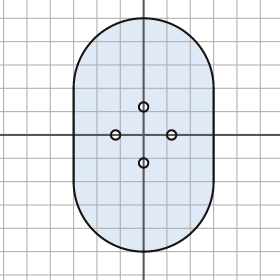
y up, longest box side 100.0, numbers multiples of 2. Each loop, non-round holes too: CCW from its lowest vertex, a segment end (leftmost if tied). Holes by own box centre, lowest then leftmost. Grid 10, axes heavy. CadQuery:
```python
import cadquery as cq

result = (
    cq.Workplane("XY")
    .moveTo(-30.0, -20.0)
    .threePointArc((0.0, -50.0), (30.0, -20.0))
    .lineTo(30.0, 20.0)
    .threePointArc((0.0, 50.0), (-30.0, 20.0))
    .close()
    .moveTo(0.0, -12.0)
    .circle(2.0)
    .moveTo(-12.0, 0.0)
    .circle(2.0)
    .moveTo(12.0, 0.0)
    .circle(2.0)
    .moveTo(0.0, 12.0)
    .circle(2.0)
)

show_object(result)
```